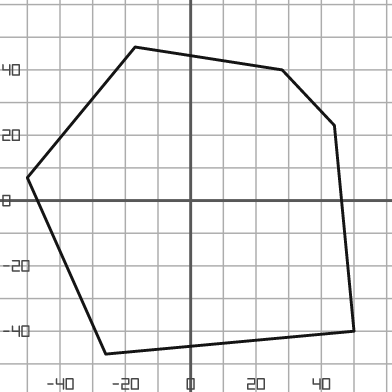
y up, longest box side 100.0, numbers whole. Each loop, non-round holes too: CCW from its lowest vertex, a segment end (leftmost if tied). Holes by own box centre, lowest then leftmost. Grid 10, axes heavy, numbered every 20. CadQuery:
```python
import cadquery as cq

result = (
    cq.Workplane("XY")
    .moveTo(-26.0, -47.0)
    .lineTo(50.0, -40.0)
    .lineTo(44.0, 23.0)
    .lineTo(28.0, 40.0)
    .lineTo(-17.0, 47.0)
    .lineTo(-50.0, 7.0)
    .close()
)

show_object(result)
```